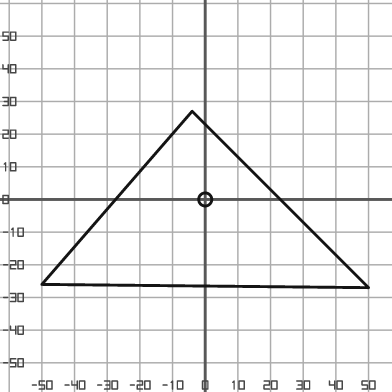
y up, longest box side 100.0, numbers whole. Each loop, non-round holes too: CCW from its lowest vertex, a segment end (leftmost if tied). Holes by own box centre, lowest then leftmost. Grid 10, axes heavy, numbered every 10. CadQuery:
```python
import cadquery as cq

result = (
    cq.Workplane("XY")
    .moveTo(50.0, -27.0)
    .lineTo(-4.0, 27.0)
    .lineTo(-50.0, -26.0)
    .close()
    .moveTo(0.0, 0.0)
    .circle(2.0)
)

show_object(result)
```